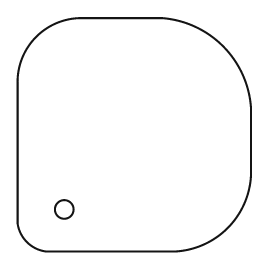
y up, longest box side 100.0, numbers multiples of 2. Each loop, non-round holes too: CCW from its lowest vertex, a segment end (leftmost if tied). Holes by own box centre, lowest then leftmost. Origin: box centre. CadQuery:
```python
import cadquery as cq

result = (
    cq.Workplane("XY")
    .moveTo(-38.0, -50.0)
    .lineTo(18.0, -50.0)
    .threePointArc((40.0, -40.0), (50.0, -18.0))
    .lineTo(50.0, 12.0)
    .threePointArc((38.0, 38.0), (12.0, 50.0))
    .lineTo(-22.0, 50.0)
    .threePointArc((-42.0, 42.0), (-50.0, 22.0))
    .lineTo(-50.0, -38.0)
    .threePointArc((-46.0, -46.0), (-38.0, -50.0))
    .close()
    .moveTo(-30.0, -32.0)
    .circle(4.0)
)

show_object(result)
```